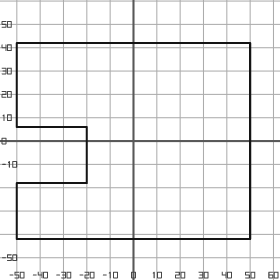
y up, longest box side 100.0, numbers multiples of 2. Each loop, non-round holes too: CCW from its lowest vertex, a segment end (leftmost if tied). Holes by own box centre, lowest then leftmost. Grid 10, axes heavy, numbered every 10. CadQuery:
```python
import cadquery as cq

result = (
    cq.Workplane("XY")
    .moveTo(-50.0, -42.0)
    .lineTo(50.0, -42.0)
    .lineTo(50.0, 42.0)
    .lineTo(-50.0, 42.0)
    .lineTo(-50.0, 6.0)
    .lineTo(-20.0, 6.0)
    .lineTo(-20.0, -18.0)
    .lineTo(-50.0, -18.0)
    .close()
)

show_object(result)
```